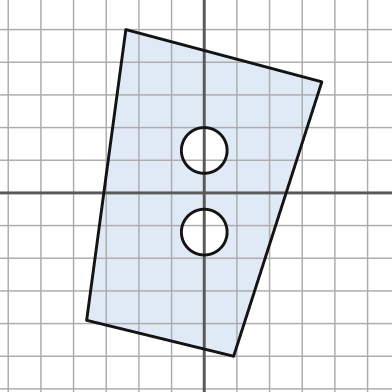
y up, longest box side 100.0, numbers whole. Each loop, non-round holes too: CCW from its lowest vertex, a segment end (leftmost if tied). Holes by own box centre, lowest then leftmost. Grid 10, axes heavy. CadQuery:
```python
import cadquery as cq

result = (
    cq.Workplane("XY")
    .moveTo(9.0, -50.0)
    .lineTo(36.0, 34.0)
    .lineTo(-24.0, 50.0)
    .lineTo(-36.0, -39.0)
    .close()
    .moveTo(0.0, -12.0)
    .circle(7.0)
    .moveTo(0.0, 13.0)
    .circle(7.0)
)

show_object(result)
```